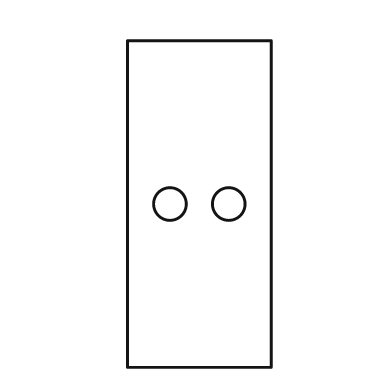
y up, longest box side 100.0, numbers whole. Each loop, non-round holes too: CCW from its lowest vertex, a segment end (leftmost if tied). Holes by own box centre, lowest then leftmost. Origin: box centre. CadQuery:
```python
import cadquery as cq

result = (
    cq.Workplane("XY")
    .moveTo(-22.0, -50.0)
    .lineTo(22.0, -50.0)
    .lineTo(22.0, 50.0)
    .lineTo(-22.0, 50.0)
    .close()
    .moveTo(-9.0, 0.0)
    .circle(5.0)
    .moveTo(9.0, 0.0)
    .circle(5.0)
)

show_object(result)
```